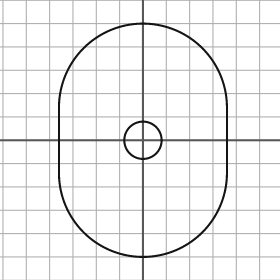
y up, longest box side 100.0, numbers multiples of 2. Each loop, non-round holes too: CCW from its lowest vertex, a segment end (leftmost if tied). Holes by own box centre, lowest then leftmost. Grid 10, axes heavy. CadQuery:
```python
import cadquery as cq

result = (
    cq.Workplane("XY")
    .moveTo(-36.0, -14.0)
    .threePointArc((0.0, -50.0), (36.0, -14.0))
    .lineTo(36.0, 14.0)
    .threePointArc((0.0, 50.0), (-36.0, 14.0))
    .close()
    .moveTo(0.0, 0.0)
    .circle(8.0)
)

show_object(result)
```